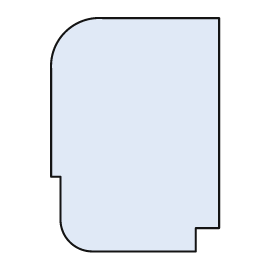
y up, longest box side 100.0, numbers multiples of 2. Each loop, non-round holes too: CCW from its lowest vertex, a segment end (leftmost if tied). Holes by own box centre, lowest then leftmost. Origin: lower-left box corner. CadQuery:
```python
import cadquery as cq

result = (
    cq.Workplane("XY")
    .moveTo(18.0, 0.0)
    .lineTo(62.0, 0.0)
    .lineTo(62.0, 10.0)
    .lineTo(72.0, 10.0)
    .lineTo(72.0, 100.0)
    .lineTo(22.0, 100.0)
    .threePointArc((6.0, 94.0), (0.0, 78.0))
    .lineTo(0.0, 32.0)
    .lineTo(4.0, 32.0)
    .lineTo(4.0, 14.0)
    .threePointArc((8.0, 4.0), (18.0, 0.0))
    .close()
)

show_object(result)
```